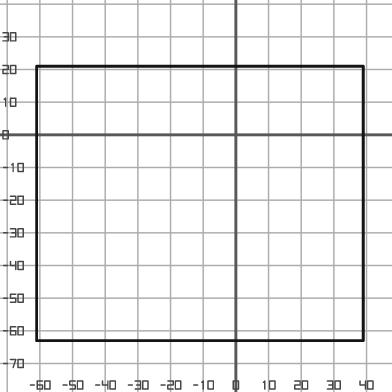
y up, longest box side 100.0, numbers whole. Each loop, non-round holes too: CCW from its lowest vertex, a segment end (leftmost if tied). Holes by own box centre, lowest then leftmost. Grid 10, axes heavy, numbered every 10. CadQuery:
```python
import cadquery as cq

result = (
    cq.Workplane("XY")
    .moveTo(-61.0, -63.0)
    .lineTo(39.0, -63.0)
    .lineTo(39.0, 21.0)
    .lineTo(-61.0, 21.0)
    .close()
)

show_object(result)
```